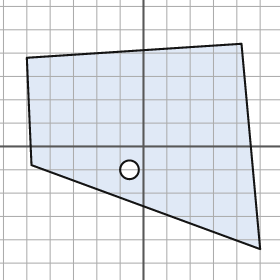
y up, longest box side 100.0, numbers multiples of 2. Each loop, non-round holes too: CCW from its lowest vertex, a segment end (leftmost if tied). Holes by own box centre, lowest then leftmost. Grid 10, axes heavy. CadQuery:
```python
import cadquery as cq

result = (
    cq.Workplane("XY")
    .moveTo(50.0, -44.0)
    .lineTo(42.0, 44.0)
    .lineTo(-50.0, 38.0)
    .lineTo(-48.0, -8.0)
    .close()
    .moveTo(-6.0, -10.0)
    .circle(4.0)
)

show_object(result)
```